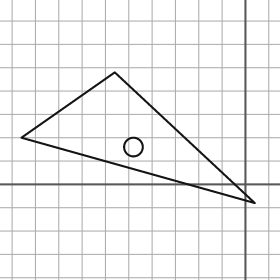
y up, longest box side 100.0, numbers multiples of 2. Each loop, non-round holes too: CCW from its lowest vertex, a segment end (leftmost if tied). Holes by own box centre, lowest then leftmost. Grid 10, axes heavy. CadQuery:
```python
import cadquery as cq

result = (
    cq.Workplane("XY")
    .moveTo(4.0, -8.0)
    .lineTo(-56.0, 48.0)
    .lineTo(-96.0, 20.0)
    .close()
    .moveTo(-48.0, 16.0)
    .circle(4.0)
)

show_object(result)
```